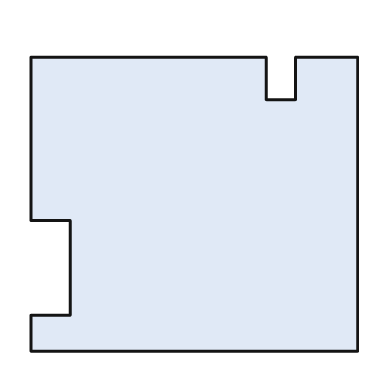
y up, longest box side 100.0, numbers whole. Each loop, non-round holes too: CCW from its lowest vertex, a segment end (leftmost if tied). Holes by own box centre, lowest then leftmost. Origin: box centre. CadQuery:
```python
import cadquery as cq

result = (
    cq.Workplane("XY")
    .moveTo(-50.0, -45.0)
    .lineTo(50.0, -45.0)
    .lineTo(50.0, 45.0)
    .lineTo(31.0, 45.0)
    .lineTo(31.0, 32.0)
    .lineTo(22.0, 32.0)
    .lineTo(22.0, 45.0)
    .lineTo(-50.0, 45.0)
    .lineTo(-50.0, -5.0)
    .lineTo(-38.0, -5.0)
    .lineTo(-38.0, -34.0)
    .lineTo(-50.0, -34.0)
    .close()
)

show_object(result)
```